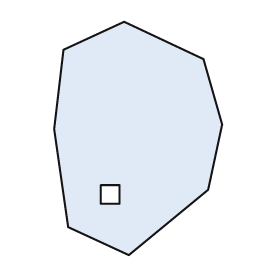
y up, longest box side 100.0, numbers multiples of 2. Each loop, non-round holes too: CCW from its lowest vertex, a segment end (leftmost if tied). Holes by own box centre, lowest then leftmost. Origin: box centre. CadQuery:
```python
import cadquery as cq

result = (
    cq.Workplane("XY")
    .moveTo(-4.0, -50.0)
    .lineTo(30.0, -22.0)
    .lineTo(36.0, 6.0)
    .lineTo(28.0, 34.0)
    .lineTo(-6.0, 50.0)
    .lineTo(-32.0, 38.0)
    .lineTo(-36.0, 4.0)
    .lineTo(-30.0, -38.0)
    .close()
    .moveTo(-16.0, -28.0)
    .lineTo(-8.0, -28.0)
    .lineTo(-8.0, -20.0)
    .lineTo(-16.0, -20.0)
    .close()
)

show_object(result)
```